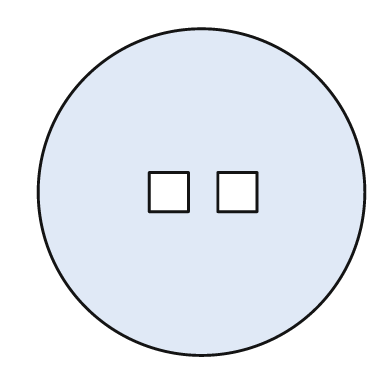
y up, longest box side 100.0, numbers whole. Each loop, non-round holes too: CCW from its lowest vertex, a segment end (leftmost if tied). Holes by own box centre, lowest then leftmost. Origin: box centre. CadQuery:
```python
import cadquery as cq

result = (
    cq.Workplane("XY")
    .moveTo(0.0, 0.0)
    .circle(50.0)
    .moveTo(-16.0, -6.0)
    .lineTo(-4.0, -6.0)
    .lineTo(-4.0, 6.0)
    .lineTo(-16.0, 6.0)
    .close()
    .moveTo(5.0, -6.0)
    .lineTo(17.0, -6.0)
    .lineTo(17.0, 6.0)
    .lineTo(5.0, 6.0)
    .close()
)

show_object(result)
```